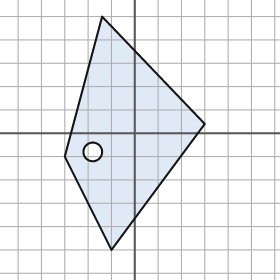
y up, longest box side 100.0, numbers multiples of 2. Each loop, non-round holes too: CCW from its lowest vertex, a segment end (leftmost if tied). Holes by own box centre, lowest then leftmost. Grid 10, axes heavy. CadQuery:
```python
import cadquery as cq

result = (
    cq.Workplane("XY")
    .moveTo(-10.0, -50.0)
    .lineTo(30.0, 4.0)
    .lineTo(-14.0, 50.0)
    .lineTo(-30.0, -10.0)
    .close()
    .moveTo(-18.0, -8.0)
    .circle(4.0)
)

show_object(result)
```